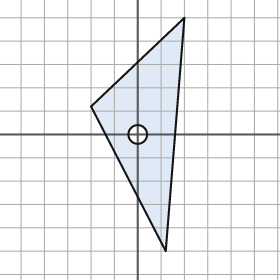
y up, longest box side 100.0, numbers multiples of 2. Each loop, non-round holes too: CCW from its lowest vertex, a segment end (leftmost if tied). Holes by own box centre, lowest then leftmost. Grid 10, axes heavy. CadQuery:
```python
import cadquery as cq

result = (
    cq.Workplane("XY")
    .moveTo(12.0, -50.0)
    .lineTo(20.0, 50.0)
    .lineTo(-20.0, 12.0)
    .close()
    .moveTo(0.0, 0.0)
    .circle(4.0)
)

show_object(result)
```